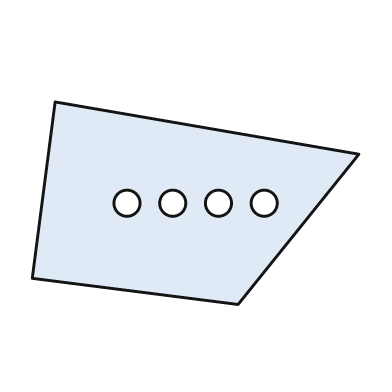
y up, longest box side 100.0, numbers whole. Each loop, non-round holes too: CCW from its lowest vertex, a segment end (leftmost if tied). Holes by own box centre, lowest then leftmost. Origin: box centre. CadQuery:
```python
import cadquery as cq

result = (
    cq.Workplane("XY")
    .moveTo(13.0, -31.0)
    .lineTo(50.0, 15.0)
    .lineTo(-43.0, 31.0)
    .lineTo(-50.0, -23.0)
    .close()
    .moveTo(-21.0, 0.0)
    .circle(4.0)
    .moveTo(-7.0, 0.0)
    .circle(4.0)
    .moveTo(7.0, 0.0)
    .circle(4.0)
    .moveTo(21.0, 0.0)
    .circle(4.0)
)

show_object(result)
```